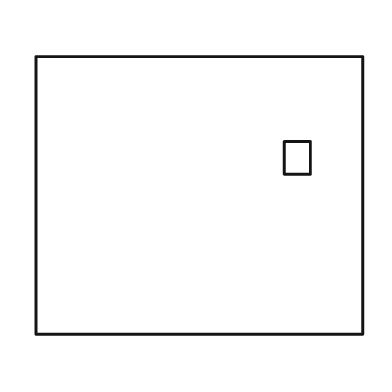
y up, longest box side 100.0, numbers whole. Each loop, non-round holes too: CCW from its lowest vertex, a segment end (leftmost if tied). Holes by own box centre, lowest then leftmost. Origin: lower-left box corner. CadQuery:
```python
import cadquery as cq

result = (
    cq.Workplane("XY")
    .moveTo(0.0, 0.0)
    .lineTo(100.0, 0.0)
    .lineTo(100.0, 85.0)
    .lineTo(0.0, 85.0)
    .close()
    .moveTo(76.0, 49.0)
    .lineTo(84.0, 49.0)
    .lineTo(84.0, 59.0)
    .lineTo(76.0, 59.0)
    .close()
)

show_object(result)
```